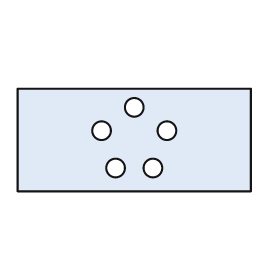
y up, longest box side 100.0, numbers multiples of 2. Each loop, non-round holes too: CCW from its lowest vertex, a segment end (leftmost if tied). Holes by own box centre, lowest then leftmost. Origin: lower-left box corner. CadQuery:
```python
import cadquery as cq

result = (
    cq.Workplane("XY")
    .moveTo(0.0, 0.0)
    .lineTo(100.0, 0.0)
    .lineTo(100.0, 44.0)
    .lineTo(0.0, 44.0)
    .close()
    .moveTo(42.0, 10.0)
    .circle(4.0)
    .moveTo(58.0, 10.0)
    .circle(4.0)
    .moveTo(36.0, 26.0)
    .circle(4.0)
    .moveTo(64.0, 26.0)
    .circle(4.0)
    .moveTo(50.0, 36.0)
    .circle(4.0)
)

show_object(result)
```